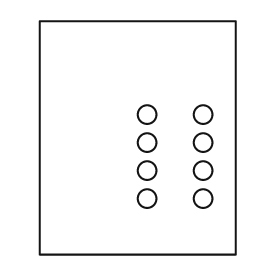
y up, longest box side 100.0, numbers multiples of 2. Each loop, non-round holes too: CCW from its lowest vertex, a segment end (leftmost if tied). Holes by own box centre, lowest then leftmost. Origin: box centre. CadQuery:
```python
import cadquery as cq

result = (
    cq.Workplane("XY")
    .moveTo(-42.0, -50.0)
    .lineTo(42.0, -50.0)
    .lineTo(42.0, 50.0)
    .lineTo(-42.0, 50.0)
    .close()
    .moveTo(4.0, -26.0)
    .circle(4.0)
    .moveTo(28.0, -26.0)
    .circle(4.0)
    .moveTo(4.0, -14.0)
    .circle(4.0)
    .moveTo(28.0, -14.0)
    .circle(4.0)
    .moveTo(4.0, -2.0)
    .circle(4.0)
    .moveTo(28.0, -2.0)
    .circle(4.0)
    .moveTo(4.0, 10.0)
    .circle(4.0)
    .moveTo(28.0, 10.0)
    .circle(4.0)
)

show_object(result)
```